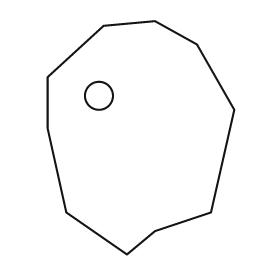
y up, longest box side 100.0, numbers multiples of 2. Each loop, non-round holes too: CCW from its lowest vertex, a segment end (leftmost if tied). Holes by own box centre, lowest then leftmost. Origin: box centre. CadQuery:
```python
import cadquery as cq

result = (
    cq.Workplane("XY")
    .moveTo(-6.0, -50.0)
    .lineTo(6.0, -40.0)
    .lineTo(30.0, -32.0)
    .lineTo(40.0, 12.0)
    .lineTo(24.0, 40.0)
    .lineTo(6.0, 50.0)
    .lineTo(-16.0, 48.0)
    .lineTo(-40.0, 26.0)
    .lineTo(-40.0, 4.0)
    .lineTo(-32.0, -32.0)
    .close()
    .moveTo(-18.0, 18.0)
    .circle(6.0)
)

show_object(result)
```